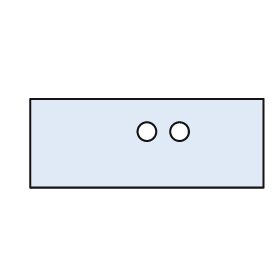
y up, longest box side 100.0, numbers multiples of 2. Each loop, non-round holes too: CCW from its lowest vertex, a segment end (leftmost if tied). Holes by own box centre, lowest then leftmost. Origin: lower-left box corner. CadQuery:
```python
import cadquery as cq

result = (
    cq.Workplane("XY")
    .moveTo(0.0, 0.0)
    .lineTo(100.0, 0.0)
    .lineTo(100.0, 38.0)
    .lineTo(0.0, 38.0)
    .close()
    .moveTo(50.0, 24.0)
    .circle(4.0)
    .moveTo(64.0, 24.0)
    .circle(4.0)
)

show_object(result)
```